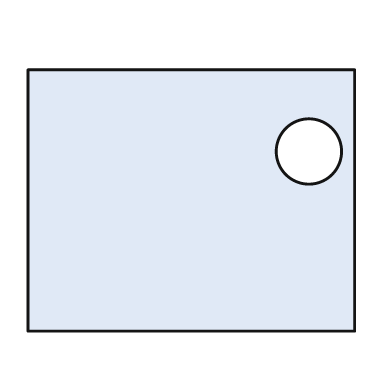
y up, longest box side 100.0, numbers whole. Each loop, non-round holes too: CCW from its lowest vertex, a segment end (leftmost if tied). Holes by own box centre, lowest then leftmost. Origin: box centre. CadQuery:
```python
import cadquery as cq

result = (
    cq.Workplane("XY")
    .moveTo(-50.0, -40.0)
    .lineTo(50.0, -40.0)
    .lineTo(50.0, 40.0)
    .lineTo(-50.0, 40.0)
    .close()
    .moveTo(36.0, 15.0)
    .circle(10.0)
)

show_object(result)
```